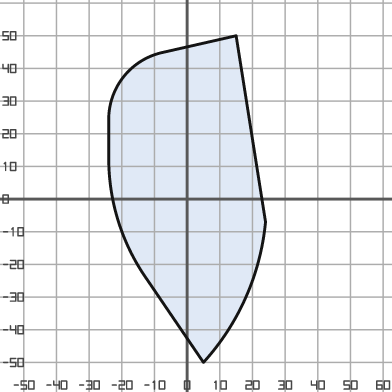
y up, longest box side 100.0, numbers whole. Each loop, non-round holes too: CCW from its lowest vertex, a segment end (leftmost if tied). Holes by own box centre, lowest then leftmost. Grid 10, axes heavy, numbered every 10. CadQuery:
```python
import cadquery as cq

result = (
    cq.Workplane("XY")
    .moveTo(5.0, -50.0)
    .threePointArc((18.0, -30.0), (24.0, -7.0))
    .lineTo(15.0, 50.0)
    .lineTo(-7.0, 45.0)
    .threePointArc((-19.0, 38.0), (-24.0, 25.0))
    .lineTo(-24.0, 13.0)
    .threePointArc((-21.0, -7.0), (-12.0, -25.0))
    .close()
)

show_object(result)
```